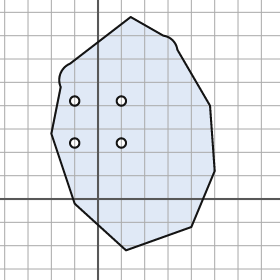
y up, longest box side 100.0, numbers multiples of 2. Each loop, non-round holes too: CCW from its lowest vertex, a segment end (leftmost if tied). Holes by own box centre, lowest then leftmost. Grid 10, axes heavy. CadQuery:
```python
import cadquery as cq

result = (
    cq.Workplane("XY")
    .moveTo(12.0, -22.0)
    .lineTo(40.0, -12.0)
    .lineTo(50.0, 12.0)
    .lineTo(48.0, 40.0)
    .lineTo(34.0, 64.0)
    .threePointArc((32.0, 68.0), (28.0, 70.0))
    .lineTo(14.0, 78.0)
    .lineTo(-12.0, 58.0)
    .threePointArc((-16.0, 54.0), (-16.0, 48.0))
    .lineTo(-20.0, 28.0)
    .lineTo(-10.0, -2.0)
    .close()
    .moveTo(-10.0, 24.0)
    .circle(2.0)
    .moveTo(10.0, 24.0)
    .circle(2.0)
    .moveTo(-10.0, 42.0)
    .circle(2.0)
    .moveTo(10.0, 42.0)
    .circle(2.0)
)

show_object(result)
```